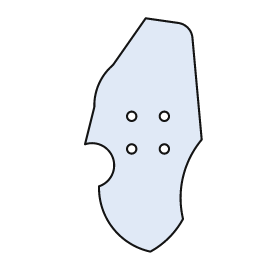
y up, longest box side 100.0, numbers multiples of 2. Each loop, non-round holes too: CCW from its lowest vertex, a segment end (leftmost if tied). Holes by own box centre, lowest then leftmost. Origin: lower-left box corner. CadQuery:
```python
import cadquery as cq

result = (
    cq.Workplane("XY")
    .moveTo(28.0, 0.0)
    .threePointArc((36.0, 6.0), (42.0, 14.0))
    .threePointArc((42.0, 32.0), (50.0, 48.0))
    .lineTo(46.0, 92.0)
    .threePointArc((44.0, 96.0), (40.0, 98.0))
    .lineTo(26.0, 100.0)
    .lineTo(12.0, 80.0)
    .threePointArc((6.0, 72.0), (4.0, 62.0))
    .lineTo(0.0, 46.0)
    .threePointArc((12.0, 40.0), (6.0, 28.0))
    .threePointArc((12.0, 10.0), (28.0, 0.0))
    .close()
    .moveTo(20.0, 44.0)
    .circle(2.0)
    .moveTo(34.0, 44.0)
    .circle(2.0)
    .moveTo(20.0, 58.0)
    .circle(2.0)
    .moveTo(34.0, 58.0)
    .circle(2.0)
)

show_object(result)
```